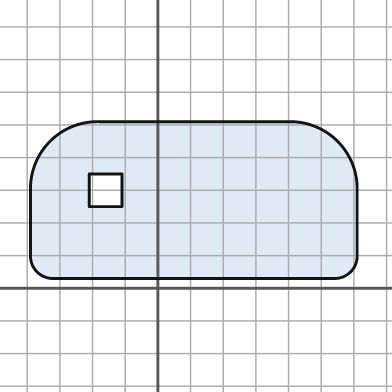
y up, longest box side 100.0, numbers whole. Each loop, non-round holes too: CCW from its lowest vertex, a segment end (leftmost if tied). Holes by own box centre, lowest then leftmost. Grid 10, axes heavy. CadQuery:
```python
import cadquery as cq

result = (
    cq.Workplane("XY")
    .moveTo(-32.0, 3.0)
    .lineTo(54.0, 3.0)
    .threePointArc((59.0, 5.0), (61.0, 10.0))
    .lineTo(61.0, 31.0)
    .threePointArc((55.0, 45.0), (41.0, 51.0))
    .lineTo(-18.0, 51.0)
    .threePointArc((-33.0, 45.0), (-39.0, 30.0))
    .lineTo(-39.0, 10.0)
    .threePointArc((-37.0, 5.0), (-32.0, 3.0))
    .close()
    .moveTo(-21.0, 25.0)
    .lineTo(-11.0, 25.0)
    .lineTo(-11.0, 35.0)
    .lineTo(-21.0, 35.0)
    .close()
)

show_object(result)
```